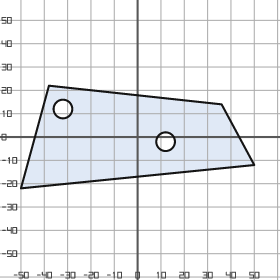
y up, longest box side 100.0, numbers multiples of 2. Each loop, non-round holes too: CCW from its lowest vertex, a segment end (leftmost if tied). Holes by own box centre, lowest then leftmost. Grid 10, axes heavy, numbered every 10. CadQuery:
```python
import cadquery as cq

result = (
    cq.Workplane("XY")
    .moveTo(-50.0, -22.0)
    .lineTo(50.0, -12.0)
    .lineTo(36.0, 14.0)
    .lineTo(-38.0, 22.0)
    .close()
    .moveTo(12.0, -2.0)
    .circle(4.0)
    .moveTo(-32.0, 12.0)
    .circle(4.0)
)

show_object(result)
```